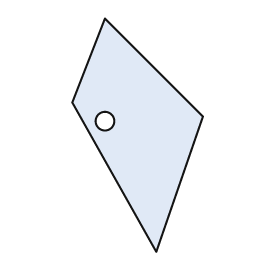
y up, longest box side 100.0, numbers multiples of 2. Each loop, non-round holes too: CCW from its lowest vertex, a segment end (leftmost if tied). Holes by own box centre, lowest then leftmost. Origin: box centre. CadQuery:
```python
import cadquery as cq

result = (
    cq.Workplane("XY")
    .moveTo(8.0, -50.0)
    .lineTo(28.0, 8.0)
    .lineTo(-14.0, 50.0)
    .lineTo(-28.0, 14.0)
    .close()
    .moveTo(-14.0, 6.0)
    .circle(4.0)
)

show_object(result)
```